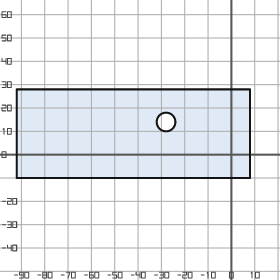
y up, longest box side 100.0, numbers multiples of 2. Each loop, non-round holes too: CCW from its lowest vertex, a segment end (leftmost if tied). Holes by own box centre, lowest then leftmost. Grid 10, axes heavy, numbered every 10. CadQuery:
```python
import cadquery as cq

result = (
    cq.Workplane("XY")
    .moveTo(-92.0, -10.0)
    .lineTo(8.0, -10.0)
    .lineTo(8.0, 28.0)
    .lineTo(-92.0, 28.0)
    .close()
    .moveTo(-28.0, 14.0)
    .circle(4.0)
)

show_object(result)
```